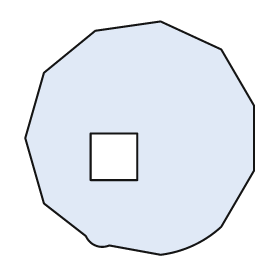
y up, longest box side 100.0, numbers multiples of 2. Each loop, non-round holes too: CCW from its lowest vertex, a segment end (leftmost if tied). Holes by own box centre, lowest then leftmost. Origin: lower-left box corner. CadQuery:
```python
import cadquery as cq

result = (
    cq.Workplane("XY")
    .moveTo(58.0, 0.0)
    .threePointArc((72.0, 4.0), (84.0, 12.0))
    .lineTo(98.0, 36.0)
    .lineTo(98.0, 64.0)
    .lineTo(84.0, 88.0)
    .lineTo(58.0, 100.0)
    .lineTo(30.0, 96.0)
    .lineTo(8.0, 78.0)
    .lineTo(0.0, 50.0)
    .lineTo(8.0, 22.0)
    .lineTo(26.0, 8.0)
    .threePointArc((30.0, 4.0), (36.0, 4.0))
    .close()
    .moveTo(28.0, 32.0)
    .lineTo(48.0, 32.0)
    .lineTo(48.0, 52.0)
    .lineTo(28.0, 52.0)
    .close()
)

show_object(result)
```